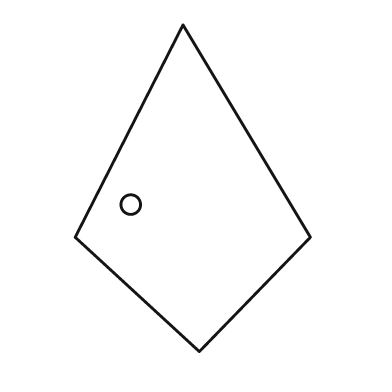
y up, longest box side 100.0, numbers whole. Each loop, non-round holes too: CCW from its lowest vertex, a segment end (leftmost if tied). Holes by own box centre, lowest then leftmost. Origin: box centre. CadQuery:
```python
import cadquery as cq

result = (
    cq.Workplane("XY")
    .moveTo(2.0, -50.0)
    .lineTo(36.0, -15.0)
    .lineTo(-3.0, 50.0)
    .lineTo(-36.0, -15.0)
    .close()
    .moveTo(-19.0, -5.0)
    .circle(3.0)
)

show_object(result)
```